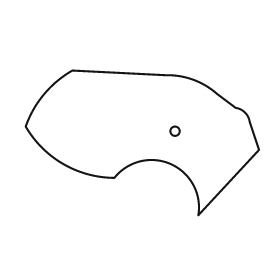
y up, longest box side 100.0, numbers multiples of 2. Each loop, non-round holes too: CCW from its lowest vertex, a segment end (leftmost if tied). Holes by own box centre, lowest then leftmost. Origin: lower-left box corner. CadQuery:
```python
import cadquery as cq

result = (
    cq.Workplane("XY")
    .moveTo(74.0, 0.0)
    .lineTo(100.0, 28.0)
    .lineTo(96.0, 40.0)
    .threePointArc((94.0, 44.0), (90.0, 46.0))
    .lineTo(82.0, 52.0)
    .threePointArc((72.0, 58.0), (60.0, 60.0))
    .lineTo(20.0, 62.0)
    .threePointArc((8.0, 52.0), (0.0, 38.0))
    .threePointArc((16.0, 22.0), (38.0, 16.0))
    .threePointArc((62.0, 22.0), (74.0, 0.0))
    .close()
    .moveTo(64.0, 36.0)
    .circle(2.0)
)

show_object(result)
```